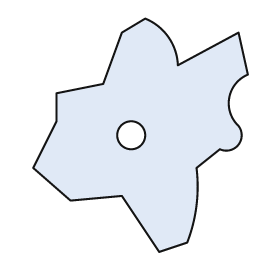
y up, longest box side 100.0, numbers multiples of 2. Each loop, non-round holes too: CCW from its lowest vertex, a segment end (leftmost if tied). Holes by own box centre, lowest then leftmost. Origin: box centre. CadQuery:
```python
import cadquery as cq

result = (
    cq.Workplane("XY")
    .moveTo(8.0, -50.0)
    .lineTo(20.0, -46.0)
    .threePointArc((24.0, -30.0), (24.0, -14.0))
    .lineTo(34.0, -6.0)
    .threePointArc((42.0, -4.0), (42.0, 4.0))
    .threePointArc((38.0, 16.0), (46.0, 26.0))
    .lineTo(42.0, 44.0)
    .lineTo(16.0, 30.0)
    .threePointArc((12.0, 42.0), (2.0, 50.0))
    .lineTo(-8.0, 44.0)
    .lineTo(-16.0, 22.0)
    .lineTo(-36.0, 18.0)
    .lineTo(-36.0, 6.0)
    .lineTo(-46.0, -14.0)
    .lineTo(-30.0, -28.0)
    .lineTo(-8.0, -26.0)
    .close()
    .moveTo(-4.0, 0.0)
    .circle(6.0)
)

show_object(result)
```